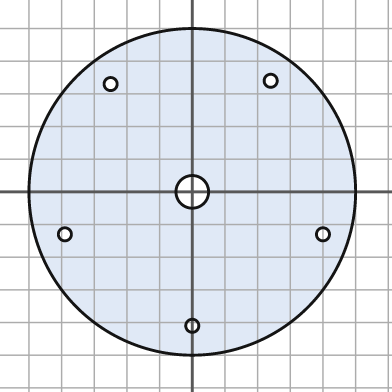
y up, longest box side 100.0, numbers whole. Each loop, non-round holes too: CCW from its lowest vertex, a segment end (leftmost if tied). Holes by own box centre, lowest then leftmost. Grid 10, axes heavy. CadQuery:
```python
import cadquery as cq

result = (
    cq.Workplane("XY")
    .moveTo(0.0, 0.0)
    .circle(50.0)
    .moveTo(0.0, -41.0)
    .circle(2.0)
    .moveTo(-39.0, -13.0)
    .circle(2.0)
    .moveTo(40.0, -13.0)
    .circle(2.0)
    .moveTo(0.0, 0.0)
    .circle(5.0)
    .moveTo(-25.0, 33.0)
    .circle(2.0)
    .moveTo(24.0, 34.0)
    .circle(2.0)
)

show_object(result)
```